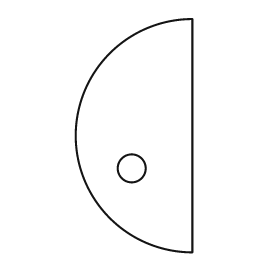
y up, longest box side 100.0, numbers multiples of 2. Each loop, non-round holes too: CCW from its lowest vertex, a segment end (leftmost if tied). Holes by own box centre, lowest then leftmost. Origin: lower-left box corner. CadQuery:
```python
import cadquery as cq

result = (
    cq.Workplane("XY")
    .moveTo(50.0, 0.0)
    .lineTo(50.0, 100.0)
    .threePointArc((0.0, 50.0), (50.0, 0.0))
    .close()
    .moveTo(24.0, 36.0)
    .circle(6.0)
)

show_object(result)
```